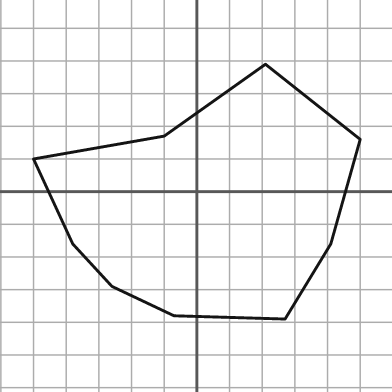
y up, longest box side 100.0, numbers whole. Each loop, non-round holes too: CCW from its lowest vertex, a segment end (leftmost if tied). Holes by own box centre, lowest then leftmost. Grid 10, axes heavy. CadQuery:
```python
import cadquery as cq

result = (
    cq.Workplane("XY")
    .moveTo(27.0, -39.0)
    .lineTo(41.0, -16.0)
    .lineTo(50.0, 16.0)
    .lineTo(21.0, 39.0)
    .lineTo(-10.0, 17.0)
    .lineTo(-50.0, 10.0)
    .lineTo(-38.0, -16.0)
    .lineTo(-26.0, -29.0)
    .lineTo(-7.0, -38.0)
    .close()
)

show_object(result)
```